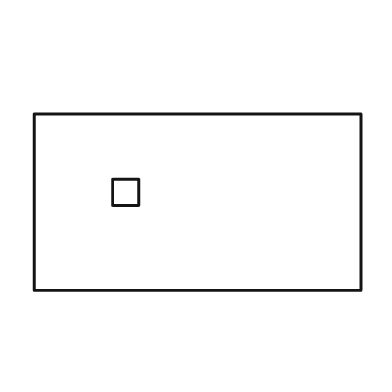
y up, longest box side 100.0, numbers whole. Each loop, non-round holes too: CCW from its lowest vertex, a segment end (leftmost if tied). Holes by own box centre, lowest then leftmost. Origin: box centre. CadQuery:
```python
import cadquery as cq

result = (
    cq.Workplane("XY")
    .moveTo(-50.0, -27.0)
    .lineTo(50.0, -27.0)
    .lineTo(50.0, 27.0)
    .lineTo(-50.0, 27.0)
    .close()
    .moveTo(-26.0, -1.0)
    .lineTo(-18.0, -1.0)
    .lineTo(-18.0, 7.0)
    .lineTo(-26.0, 7.0)
    .close()
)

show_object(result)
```